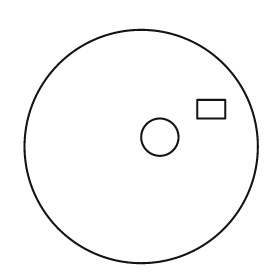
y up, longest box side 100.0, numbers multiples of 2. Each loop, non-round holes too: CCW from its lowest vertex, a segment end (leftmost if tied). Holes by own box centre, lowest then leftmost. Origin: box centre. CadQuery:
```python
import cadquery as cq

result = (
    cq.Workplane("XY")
    .moveTo(0.0, 0.0)
    .circle(50.0)
    .moveTo(8.0, 4.0)
    .circle(8.0)
    .moveTo(24.0, 12.0)
    .lineTo(36.0, 12.0)
    .lineTo(36.0, 20.0)
    .lineTo(24.0, 20.0)
    .close()
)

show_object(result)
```